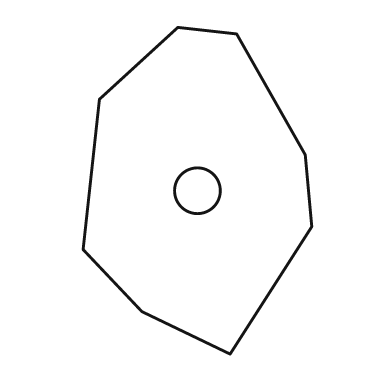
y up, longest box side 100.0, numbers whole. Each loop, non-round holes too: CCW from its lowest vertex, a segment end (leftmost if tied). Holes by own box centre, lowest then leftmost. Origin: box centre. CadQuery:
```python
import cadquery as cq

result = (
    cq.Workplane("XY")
    .moveTo(10.0, -50.0)
    .lineTo(35.0, -11.0)
    .lineTo(33.0, 11.0)
    .lineTo(12.0, 48.0)
    .lineTo(-6.0, 50.0)
    .lineTo(-30.0, 28.0)
    .lineTo(-35.0, -18.0)
    .lineTo(-17.0, -37.0)
    .close()
    .moveTo(0.0, 0.0)
    .circle(7.0)
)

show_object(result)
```